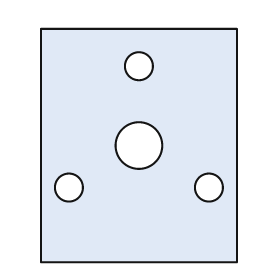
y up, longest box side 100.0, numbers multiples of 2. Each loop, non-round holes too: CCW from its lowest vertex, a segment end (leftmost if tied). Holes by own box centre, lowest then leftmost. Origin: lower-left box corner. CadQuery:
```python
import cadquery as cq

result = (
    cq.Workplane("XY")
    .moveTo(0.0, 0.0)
    .lineTo(84.0, 0.0)
    .lineTo(84.0, 100.0)
    .lineTo(0.0, 100.0)
    .close()
    .moveTo(12.0, 32.0)
    .circle(6.0)
    .moveTo(72.0, 32.0)
    .circle(6.0)
    .moveTo(42.0, 50.0)
    .circle(10.0)
    .moveTo(42.0, 84.0)
    .circle(6.0)
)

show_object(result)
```